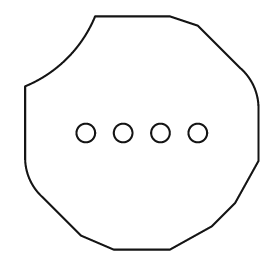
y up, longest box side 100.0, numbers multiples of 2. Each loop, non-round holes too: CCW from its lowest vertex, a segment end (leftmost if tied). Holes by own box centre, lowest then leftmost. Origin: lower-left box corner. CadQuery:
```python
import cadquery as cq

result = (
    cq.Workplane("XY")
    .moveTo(38.0, 0.0)
    .lineTo(62.0, 0.0)
    .lineTo(80.0, 10.0)
    .lineTo(90.0, 20.0)
    .lineTo(100.0, 38.0)
    .lineTo(100.0, 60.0)
    .threePointArc((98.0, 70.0), (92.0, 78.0))
    .lineTo(74.0, 96.0)
    .lineTo(62.0, 100.0)
    .lineTo(30.0, 100.0)
    .threePointArc((18.0, 82.0), (0.0, 70.0))
    .lineTo(0.0, 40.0)
    .threePointArc((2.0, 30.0), (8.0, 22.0))
    .lineTo(24.0, 6.0)
    .close()
    .moveTo(26.0, 50.0)
    .circle(4.0)
    .moveTo(42.0, 50.0)
    .circle(4.0)
    .moveTo(58.0, 50.0)
    .circle(4.0)
    .moveTo(74.0, 50.0)
    .circle(4.0)
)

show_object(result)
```